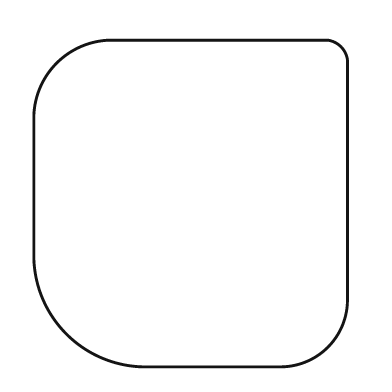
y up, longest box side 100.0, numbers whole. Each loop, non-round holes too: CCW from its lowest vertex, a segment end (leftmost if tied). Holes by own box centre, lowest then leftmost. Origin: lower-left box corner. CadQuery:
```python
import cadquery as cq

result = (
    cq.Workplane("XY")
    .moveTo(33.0, 0.0)
    .lineTo(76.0, 0.0)
    .threePointArc((90.0, 6.0), (96.0, 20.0))
    .lineTo(96.0, 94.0)
    .threePointArc((94.0, 98.0), (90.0, 100.0))
    .lineTo(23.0, 100.0)
    .threePointArc((7.0, 93.0), (0.0, 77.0))
    .lineTo(0.0, 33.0)
    .threePointArc((10.0, 10.0), (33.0, 0.0))
    .close()
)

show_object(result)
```